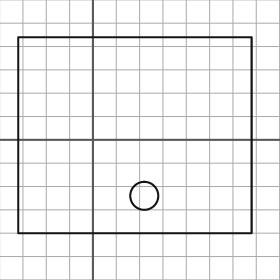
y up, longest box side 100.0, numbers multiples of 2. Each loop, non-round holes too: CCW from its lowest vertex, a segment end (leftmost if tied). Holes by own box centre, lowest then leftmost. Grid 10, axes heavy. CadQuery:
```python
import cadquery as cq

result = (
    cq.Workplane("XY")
    .moveTo(-32.0, -40.0)
    .lineTo(68.0, -40.0)
    .lineTo(68.0, 44.0)
    .lineTo(-32.0, 44.0)
    .close()
    .moveTo(22.0, -24.0)
    .circle(6.0)
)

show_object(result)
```